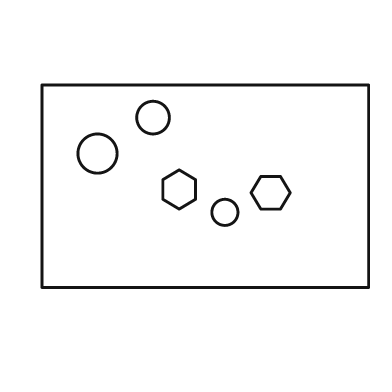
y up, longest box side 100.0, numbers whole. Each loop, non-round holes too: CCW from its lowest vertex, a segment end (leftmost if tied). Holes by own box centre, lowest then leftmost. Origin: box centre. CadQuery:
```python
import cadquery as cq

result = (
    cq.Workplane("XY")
    .moveTo(-50.0, -31.0)
    .lineTo(50.0, -31.0)
    .lineTo(50.0, 31.0)
    .lineTo(-50.0, 31.0)
    .close()
    .moveTo(6.0, -8.0)
    .circle(4.0)
    .moveTo(17.0, -7.0)
    .lineTo(23.0, -7.0)
    .lineTo(26.0, -2.0)
    .lineTo(23.0, 3.0)
    .lineTo(17.0, 3.0)
    .lineTo(14.0, -2.0)
    .close()
    .moveTo(-8.0, -7.0)
    .lineTo(-3.0, -4.0)
    .lineTo(-3.0, 2.0)
    .lineTo(-8.0, 5.0)
    .lineTo(-13.0, 2.0)
    .lineTo(-13.0, -4.0)
    .close()
    .moveTo(-33.0, 10.0)
    .circle(6.0)
    .moveTo(-16.0, 21.0)
    .circle(5.0)
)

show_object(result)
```